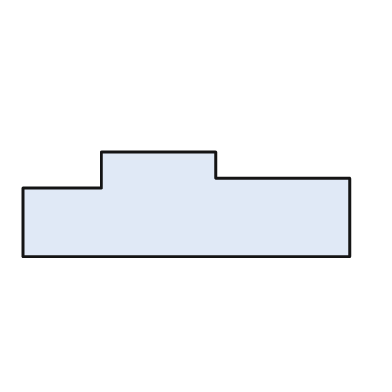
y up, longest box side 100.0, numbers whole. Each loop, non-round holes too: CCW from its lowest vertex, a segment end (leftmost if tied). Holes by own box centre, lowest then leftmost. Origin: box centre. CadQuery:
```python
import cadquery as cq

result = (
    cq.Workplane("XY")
    .moveTo(-50.0, -16.0)
    .lineTo(50.0, -16.0)
    .lineTo(50.0, 8.0)
    .lineTo(9.0, 8.0)
    .lineTo(9.0, 16.0)
    .lineTo(-26.0, 16.0)
    .lineTo(-26.0, 5.0)
    .lineTo(-50.0, 5.0)
    .close()
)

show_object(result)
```